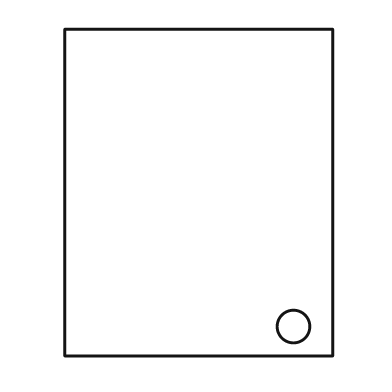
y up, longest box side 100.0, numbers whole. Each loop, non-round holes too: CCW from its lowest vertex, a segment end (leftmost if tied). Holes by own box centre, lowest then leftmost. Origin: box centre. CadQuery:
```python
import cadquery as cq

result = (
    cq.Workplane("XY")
    .moveTo(-41.0, -50.0)
    .lineTo(41.0, -50.0)
    .lineTo(41.0, 50.0)
    .lineTo(-41.0, 50.0)
    .close()
    .moveTo(29.0, -41.0)
    .circle(5.0)
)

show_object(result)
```